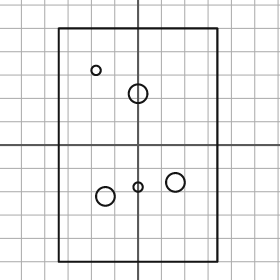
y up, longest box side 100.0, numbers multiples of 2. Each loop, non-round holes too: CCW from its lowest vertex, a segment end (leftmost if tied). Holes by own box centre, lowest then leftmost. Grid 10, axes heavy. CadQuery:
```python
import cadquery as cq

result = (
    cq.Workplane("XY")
    .moveTo(-34.0, -50.0)
    .lineTo(34.0, -50.0)
    .lineTo(34.0, 50.0)
    .lineTo(-34.0, 50.0)
    .close()
    .moveTo(-14.0, -22.0)
    .circle(4.0)
    .moveTo(0.0, -18.0)
    .circle(2.0)
    .moveTo(16.0, -16.0)
    .circle(4.0)
    .moveTo(0.0, 22.0)
    .circle(4.0)
    .moveTo(-18.0, 32.0)
    .circle(2.0)
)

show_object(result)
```